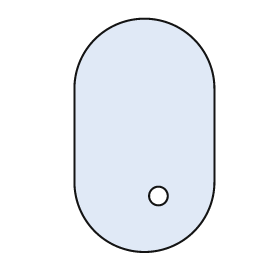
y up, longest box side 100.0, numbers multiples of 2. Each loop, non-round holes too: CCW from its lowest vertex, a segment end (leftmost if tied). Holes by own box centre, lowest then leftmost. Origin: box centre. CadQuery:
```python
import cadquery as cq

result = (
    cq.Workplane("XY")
    .moveTo(-30.0, -20.0)
    .threePointArc((0.0, -50.0), (30.0, -20.0))
    .lineTo(30.0, 20.0)
    .threePointArc((0.0, 50.0), (-30.0, 20.0))
    .close()
    .moveTo(6.0, -26.0)
    .circle(4.0)
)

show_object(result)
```